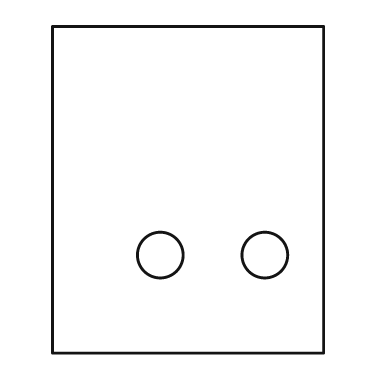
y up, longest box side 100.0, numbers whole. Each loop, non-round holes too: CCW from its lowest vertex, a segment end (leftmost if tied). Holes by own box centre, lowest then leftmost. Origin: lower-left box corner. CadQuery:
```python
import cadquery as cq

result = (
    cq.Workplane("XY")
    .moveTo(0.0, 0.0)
    .lineTo(83.0, 0.0)
    .lineTo(83.0, 100.0)
    .lineTo(0.0, 100.0)
    .close()
    .moveTo(33.0, 30.0)
    .circle(7.0)
    .moveTo(65.0, 30.0)
    .circle(7.0)
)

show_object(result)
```